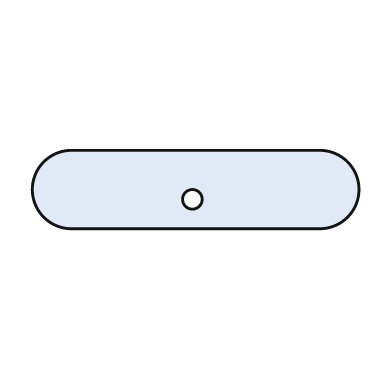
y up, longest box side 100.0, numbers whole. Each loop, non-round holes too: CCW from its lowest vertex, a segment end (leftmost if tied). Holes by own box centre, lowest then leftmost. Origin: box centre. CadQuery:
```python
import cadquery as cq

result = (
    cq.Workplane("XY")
    .moveTo(-38.0, -12.0)
    .lineTo(38.0, -12.0)
    .threePointArc((50.0, 0.0), (38.0, 12.0))
    .lineTo(-38.0, 12.0)
    .threePointArc((-50.0, 0.0), (-38.0, -12.0))
    .close()
    .moveTo(-1.0, -3.0)
    .circle(3.0)
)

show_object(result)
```